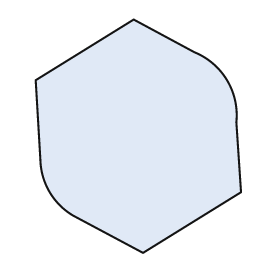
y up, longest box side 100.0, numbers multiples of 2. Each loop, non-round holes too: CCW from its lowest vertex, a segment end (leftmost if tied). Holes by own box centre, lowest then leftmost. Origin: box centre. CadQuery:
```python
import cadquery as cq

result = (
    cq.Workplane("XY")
    .moveTo(2.0, -50.0)
    .lineTo(44.0, -24.0)
    .lineTo(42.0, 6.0)
    .threePointArc((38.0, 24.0), (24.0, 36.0))
    .lineTo(-2.0, 50.0)
    .lineTo(-44.0, 24.0)
    .lineTo(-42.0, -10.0)
    .threePointArc((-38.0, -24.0), (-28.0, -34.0))
    .close()
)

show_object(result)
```